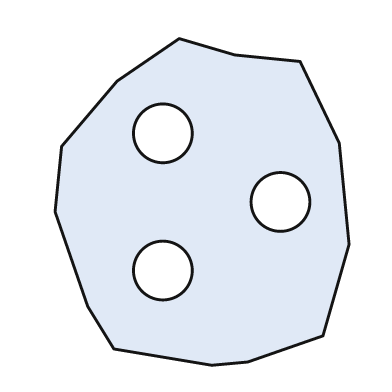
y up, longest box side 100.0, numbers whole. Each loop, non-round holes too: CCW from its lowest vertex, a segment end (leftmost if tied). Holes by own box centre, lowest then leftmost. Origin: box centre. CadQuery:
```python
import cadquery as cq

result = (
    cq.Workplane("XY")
    .moveTo(3.0, -50.0)
    .lineTo(14.0, -49.0)
    .lineTo(37.0, -41.0)
    .lineTo(45.0, -13.0)
    .lineTo(42.0, 18.0)
    .lineTo(30.0, 43.0)
    .lineTo(10.0, 45.0)
    .lineTo(-7.0, 50.0)
    .lineTo(-26.0, 37.0)
    .lineTo(-43.0, 17.0)
    .lineTo(-45.0, -3.0)
    .lineTo(-35.0, -32.0)
    .lineTo(-27.0, -45.0)
    .close()
    .moveTo(-12.0, -21.0)
    .circle(9.0)
    .moveTo(24.0, 0.0)
    .circle(9.0)
    .moveTo(-12.0, 21.0)
    .circle(9.0)
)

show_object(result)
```